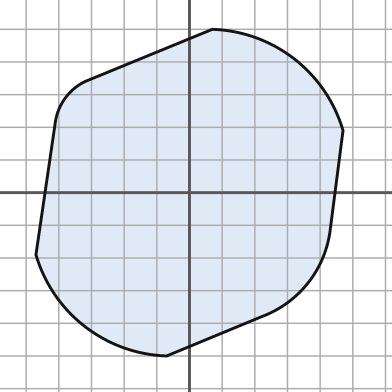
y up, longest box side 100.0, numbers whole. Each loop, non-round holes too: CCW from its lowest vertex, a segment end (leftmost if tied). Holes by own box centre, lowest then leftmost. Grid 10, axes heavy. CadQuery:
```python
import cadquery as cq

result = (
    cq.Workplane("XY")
    .moveTo(-7.0, -50.0)
    .lineTo(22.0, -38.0)
    .threePointArc((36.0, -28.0), (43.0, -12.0))
    .lineTo(47.0, 19.0)
    .threePointArc((32.0, 41.0), (7.0, 50.0))
    .lineTo(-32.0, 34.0)
    .threePointArc((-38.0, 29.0), (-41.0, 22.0))
    .lineTo(-47.0, -19.0)
    .threePointArc((-32.0, -41.0), (-7.0, -50.0))
    .close()
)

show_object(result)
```